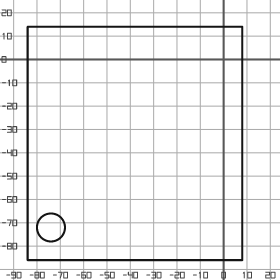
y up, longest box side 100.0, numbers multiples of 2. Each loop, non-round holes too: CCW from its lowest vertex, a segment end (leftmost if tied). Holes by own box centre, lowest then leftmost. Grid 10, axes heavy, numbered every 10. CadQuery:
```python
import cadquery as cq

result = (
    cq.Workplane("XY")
    .moveTo(-84.0, -86.0)
    .lineTo(8.0, -86.0)
    .lineTo(8.0, 14.0)
    .lineTo(-84.0, 14.0)
    .close()
    .moveTo(-74.0, -72.0)
    .circle(6.0)
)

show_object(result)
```